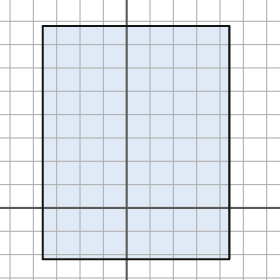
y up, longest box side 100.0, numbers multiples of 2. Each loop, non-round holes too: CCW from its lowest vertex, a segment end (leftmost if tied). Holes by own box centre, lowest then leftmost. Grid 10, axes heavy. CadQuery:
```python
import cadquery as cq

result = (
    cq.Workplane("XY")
    .moveTo(-36.0, -22.0)
    .lineTo(44.0, -22.0)
    .lineTo(44.0, 78.0)
    .lineTo(-36.0, 78.0)
    .close()
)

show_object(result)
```